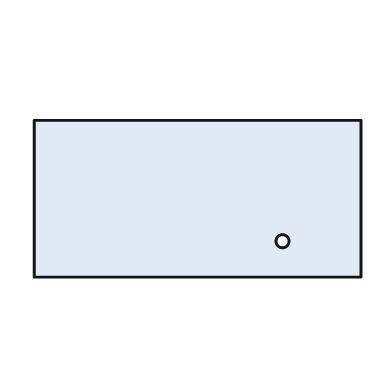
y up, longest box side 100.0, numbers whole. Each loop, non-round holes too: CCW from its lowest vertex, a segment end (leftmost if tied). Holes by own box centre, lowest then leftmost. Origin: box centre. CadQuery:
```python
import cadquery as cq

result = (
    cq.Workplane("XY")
    .moveTo(-50.0, -24.0)
    .lineTo(50.0, -24.0)
    .lineTo(50.0, 24.0)
    .lineTo(-50.0, 24.0)
    .close()
    .moveTo(26.0, -13.0)
    .circle(2.0)
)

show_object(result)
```